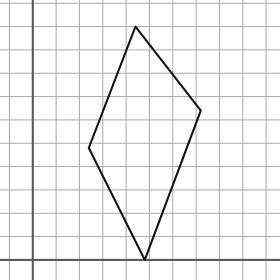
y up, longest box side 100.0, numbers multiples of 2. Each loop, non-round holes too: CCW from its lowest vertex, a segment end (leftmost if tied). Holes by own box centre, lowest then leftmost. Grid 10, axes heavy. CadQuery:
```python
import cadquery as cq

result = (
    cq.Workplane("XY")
    .moveTo(48.0, 0.0)
    .lineTo(72.0, 64.0)
    .lineTo(44.0, 100.0)
    .lineTo(24.0, 48.0)
    .close()
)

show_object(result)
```